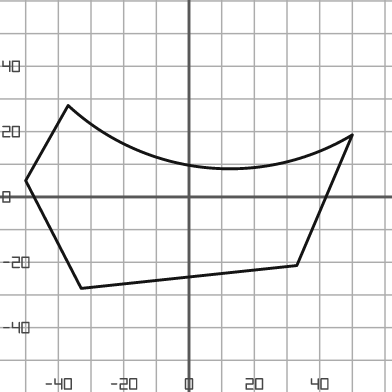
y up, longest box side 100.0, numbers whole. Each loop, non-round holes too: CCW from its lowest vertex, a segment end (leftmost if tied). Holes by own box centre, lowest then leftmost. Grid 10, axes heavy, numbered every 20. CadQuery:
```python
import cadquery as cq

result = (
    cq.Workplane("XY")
    .moveTo(-33.0, -28.0)
    .lineTo(33.0, -21.0)
    .lineTo(50.0, 19.0)
    .threePointArc((5.0, 9.0), (-37.0, 28.0))
    .lineTo(-50.0, 5.0)
    .close()
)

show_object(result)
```